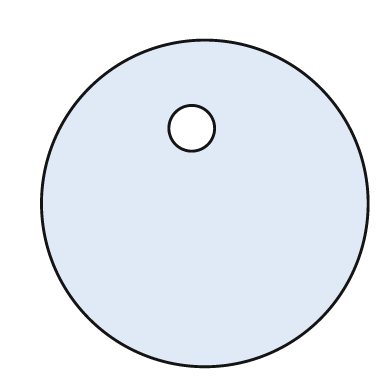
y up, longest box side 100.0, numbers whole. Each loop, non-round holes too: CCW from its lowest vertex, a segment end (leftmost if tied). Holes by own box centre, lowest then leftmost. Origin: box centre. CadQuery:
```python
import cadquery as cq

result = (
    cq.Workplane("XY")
    .moveTo(0.0, 0.0)
    .circle(50.0)
    .moveTo(-4.0, 23.0)
    .circle(7.0)
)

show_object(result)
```